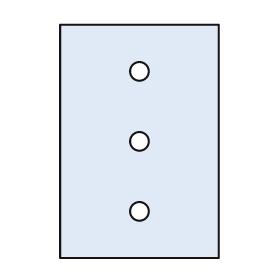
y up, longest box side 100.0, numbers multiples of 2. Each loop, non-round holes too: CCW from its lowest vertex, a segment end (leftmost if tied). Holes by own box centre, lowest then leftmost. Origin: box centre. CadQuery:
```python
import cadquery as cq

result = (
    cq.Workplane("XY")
    .moveTo(-34.0, -50.0)
    .lineTo(34.0, -50.0)
    .lineTo(34.0, 50.0)
    .lineTo(-34.0, 50.0)
    .close()
    .moveTo(0.0, -30.0)
    .circle(4.0)
    .moveTo(0.0, 0.0)
    .circle(4.0)
    .moveTo(0.0, 30.0)
    .circle(4.0)
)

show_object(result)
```